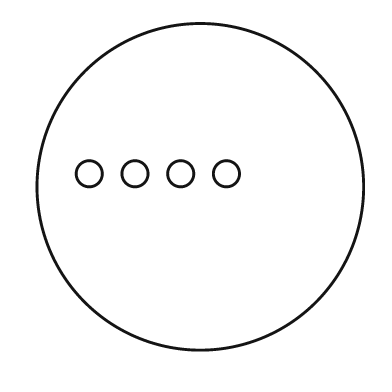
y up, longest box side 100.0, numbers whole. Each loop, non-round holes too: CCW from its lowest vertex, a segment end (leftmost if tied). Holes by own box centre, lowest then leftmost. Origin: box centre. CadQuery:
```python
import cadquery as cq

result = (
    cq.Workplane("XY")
    .moveTo(0.0, 0.0)
    .circle(50.0)
    .moveTo(-34.0, 4.0)
    .circle(4.0)
    .moveTo(-20.0, 4.0)
    .circle(4.0)
    .moveTo(-6.0, 4.0)
    .circle(4.0)
    .moveTo(8.0, 4.0)
    .circle(4.0)
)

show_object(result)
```